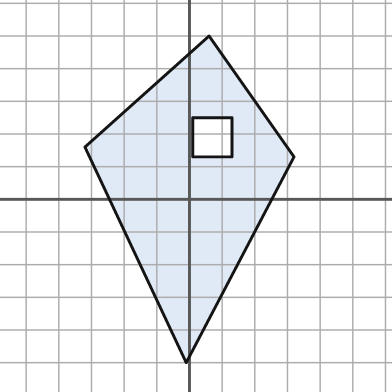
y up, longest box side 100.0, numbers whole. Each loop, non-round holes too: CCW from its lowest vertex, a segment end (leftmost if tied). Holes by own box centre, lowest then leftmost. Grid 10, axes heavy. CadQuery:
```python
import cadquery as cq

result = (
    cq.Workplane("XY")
    .moveTo(-1.0, -50.0)
    .lineTo(32.0, 13.0)
    .lineTo(6.0, 50.0)
    .lineTo(-32.0, 16.0)
    .close()
    .moveTo(1.0, 13.0)
    .lineTo(13.0, 13.0)
    .lineTo(13.0, 25.0)
    .lineTo(1.0, 25.0)
    .close()
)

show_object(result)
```